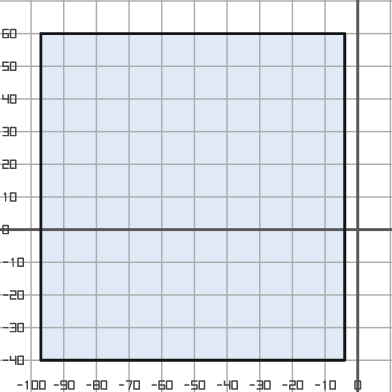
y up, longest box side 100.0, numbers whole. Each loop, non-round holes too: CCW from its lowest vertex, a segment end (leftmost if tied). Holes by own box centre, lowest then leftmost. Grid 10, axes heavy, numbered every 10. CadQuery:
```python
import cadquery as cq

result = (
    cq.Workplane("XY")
    .moveTo(-97.0, -40.0)
    .lineTo(-4.0, -40.0)
    .lineTo(-4.0, 60.0)
    .lineTo(-97.0, 60.0)
    .close()
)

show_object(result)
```